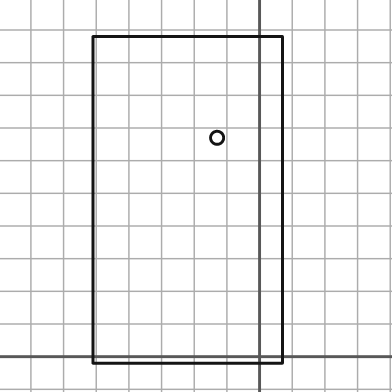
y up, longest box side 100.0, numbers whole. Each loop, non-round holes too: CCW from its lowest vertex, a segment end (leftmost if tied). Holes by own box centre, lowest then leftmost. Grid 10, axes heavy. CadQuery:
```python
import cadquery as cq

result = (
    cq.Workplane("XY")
    .moveTo(-51.0, -2.0)
    .lineTo(7.0, -2.0)
    .lineTo(7.0, 98.0)
    .lineTo(-51.0, 98.0)
    .close()
    .moveTo(-13.0, 67.0)
    .circle(2.0)
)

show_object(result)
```